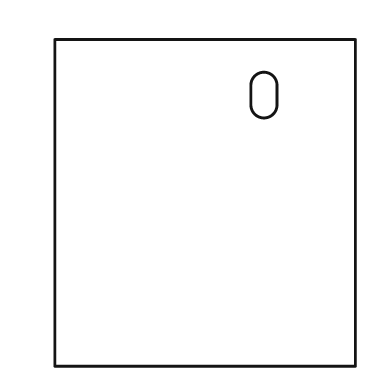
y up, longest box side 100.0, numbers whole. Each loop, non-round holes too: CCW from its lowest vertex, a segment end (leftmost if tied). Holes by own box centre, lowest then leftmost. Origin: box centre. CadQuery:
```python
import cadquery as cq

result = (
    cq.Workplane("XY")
    .moveTo(-46.0, -50.0)
    .lineTo(46.0, -50.0)
    .lineTo(46.0, 50.0)
    .lineTo(-46.0, 50.0)
    .close()
    .moveTo(14.0, 30.0)
    .threePointArc((18.0, 26.0), (22.0, 30.0))
    .lineTo(22.0, 36.0)
    .threePointArc((18.0, 40.0), (14.0, 36.0))
    .close()
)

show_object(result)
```